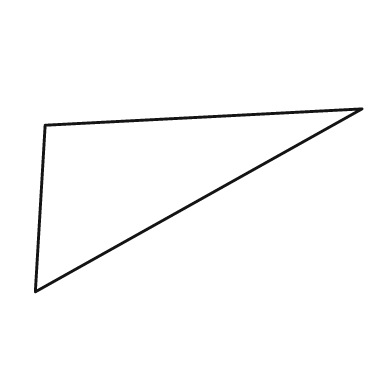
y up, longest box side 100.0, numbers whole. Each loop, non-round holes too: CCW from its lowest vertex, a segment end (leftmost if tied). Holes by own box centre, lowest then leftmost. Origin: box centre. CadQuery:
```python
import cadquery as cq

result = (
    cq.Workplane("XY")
    .moveTo(-50.0, -28.0)
    .lineTo(50.0, 28.0)
    .lineTo(-47.0, 23.0)
    .close()
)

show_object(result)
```